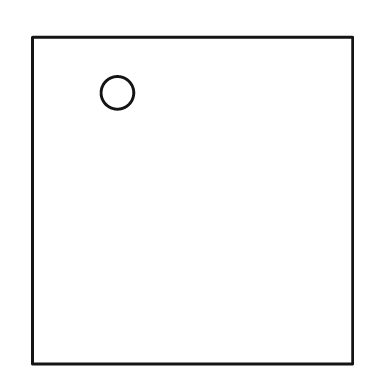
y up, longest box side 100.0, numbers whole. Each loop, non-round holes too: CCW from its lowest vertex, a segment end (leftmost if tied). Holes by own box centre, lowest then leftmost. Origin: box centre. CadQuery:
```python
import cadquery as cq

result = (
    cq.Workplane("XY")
    .moveTo(-49.0, -50.0)
    .lineTo(49.0, -50.0)
    .lineTo(49.0, 50.0)
    .lineTo(-49.0, 50.0)
    .close()
    .moveTo(-23.0, 33.0)
    .circle(5.0)
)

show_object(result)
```